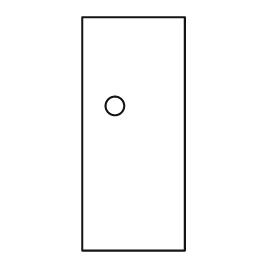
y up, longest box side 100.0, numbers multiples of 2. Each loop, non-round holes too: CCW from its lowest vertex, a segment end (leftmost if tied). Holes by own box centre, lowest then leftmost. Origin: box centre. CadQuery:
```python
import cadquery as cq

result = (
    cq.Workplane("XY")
    .moveTo(-22.0, -50.0)
    .lineTo(22.0, -50.0)
    .lineTo(22.0, 50.0)
    .lineTo(-22.0, 50.0)
    .close()
    .moveTo(-8.0, 12.0)
    .circle(4.0)
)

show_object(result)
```